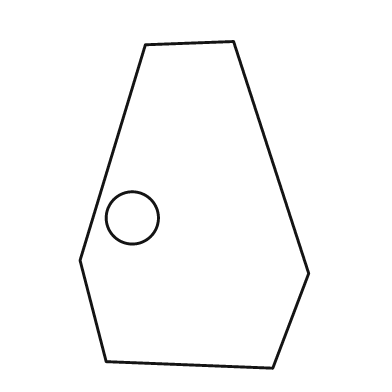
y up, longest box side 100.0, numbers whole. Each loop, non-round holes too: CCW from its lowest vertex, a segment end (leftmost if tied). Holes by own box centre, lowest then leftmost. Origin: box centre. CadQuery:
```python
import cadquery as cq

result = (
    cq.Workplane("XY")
    .moveTo(24.0, -50.0)
    .lineTo(35.0, -21.0)
    .lineTo(12.0, 50.0)
    .lineTo(-15.0, 49.0)
    .lineTo(-35.0, -17.0)
    .lineTo(-27.0, -48.0)
    .close()
    .moveTo(-19.0, -4.0)
    .circle(8.0)
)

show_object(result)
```